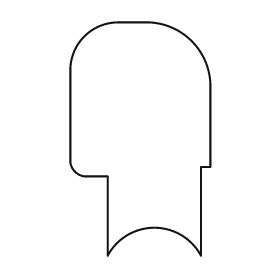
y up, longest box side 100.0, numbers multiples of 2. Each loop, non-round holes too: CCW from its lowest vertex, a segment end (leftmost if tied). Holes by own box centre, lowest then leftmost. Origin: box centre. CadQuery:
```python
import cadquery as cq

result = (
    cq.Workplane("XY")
    .moveTo(-14.0, -50.0)
    .threePointArc((6.0, -38.0), (26.0, -50.0))
    .lineTo(26.0, -12.0)
    .lineTo(30.0, -12.0)
    .lineTo(30.0, 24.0)
    .threePointArc((22.0, 42.0), (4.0, 50.0))
    .lineTo(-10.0, 50.0)
    .threePointArc((-24.0, 44.0), (-30.0, 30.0))
    .lineTo(-30.0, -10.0)
    .threePointArc((-28.0, -14.0), (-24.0, -16.0))
    .lineTo(-14.0, -16.0)
    .close()
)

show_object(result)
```